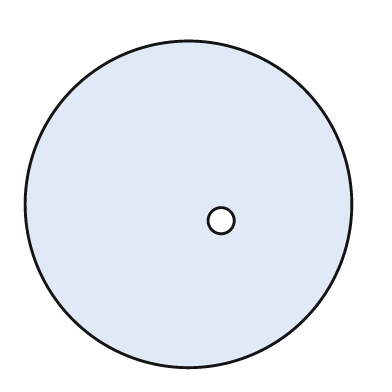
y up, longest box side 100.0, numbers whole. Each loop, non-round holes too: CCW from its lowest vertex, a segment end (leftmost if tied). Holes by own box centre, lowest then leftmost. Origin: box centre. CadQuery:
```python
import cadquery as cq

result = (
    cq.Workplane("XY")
    .moveTo(0.0, 0.0)
    .circle(50.0)
    .moveTo(10.0, -5.0)
    .circle(4.0)
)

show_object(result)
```